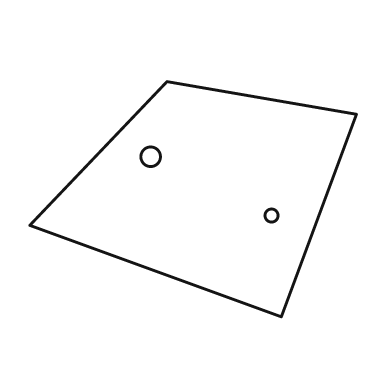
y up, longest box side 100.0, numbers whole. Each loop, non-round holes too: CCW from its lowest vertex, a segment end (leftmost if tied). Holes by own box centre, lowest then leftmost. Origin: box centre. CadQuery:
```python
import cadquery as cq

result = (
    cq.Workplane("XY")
    .moveTo(27.0, -36.0)
    .lineTo(50.0, 26.0)
    .lineTo(-8.0, 36.0)
    .lineTo(-50.0, -8.0)
    .close()
    .moveTo(24.0, -5.0)
    .circle(2.0)
    .moveTo(-13.0, 13.0)
    .circle(3.0)
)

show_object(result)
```